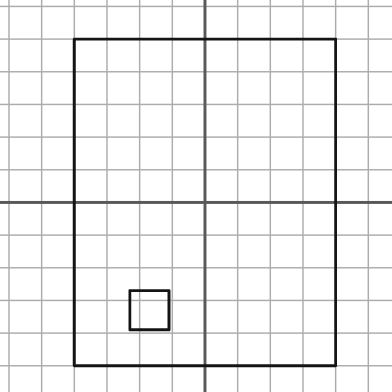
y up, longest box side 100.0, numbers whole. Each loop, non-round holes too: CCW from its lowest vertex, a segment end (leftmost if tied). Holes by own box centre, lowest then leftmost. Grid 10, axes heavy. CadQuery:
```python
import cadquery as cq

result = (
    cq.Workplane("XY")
    .moveTo(-40.0, -50.0)
    .lineTo(40.0, -50.0)
    .lineTo(40.0, 50.0)
    .lineTo(-40.0, 50.0)
    .close()
    .moveTo(-23.0, -39.0)
    .lineTo(-11.0, -39.0)
    .lineTo(-11.0, -27.0)
    .lineTo(-23.0, -27.0)
    .close()
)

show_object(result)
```